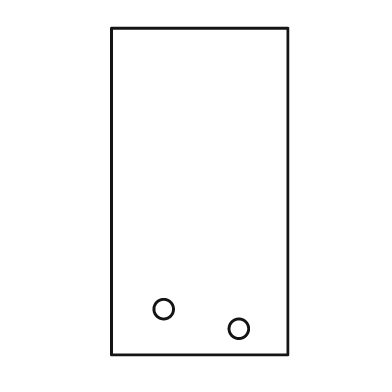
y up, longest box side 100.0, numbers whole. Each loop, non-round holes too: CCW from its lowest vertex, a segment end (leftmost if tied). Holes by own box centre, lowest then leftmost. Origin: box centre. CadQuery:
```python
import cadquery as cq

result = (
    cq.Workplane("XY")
    .moveTo(-27.0, -50.0)
    .lineTo(27.0, -50.0)
    .lineTo(27.0, 50.0)
    .lineTo(-27.0, 50.0)
    .close()
    .moveTo(12.0, -42.0)
    .circle(3.0)
    .moveTo(-11.0, -36.0)
    .circle(3.0)
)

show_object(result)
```